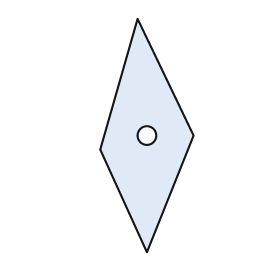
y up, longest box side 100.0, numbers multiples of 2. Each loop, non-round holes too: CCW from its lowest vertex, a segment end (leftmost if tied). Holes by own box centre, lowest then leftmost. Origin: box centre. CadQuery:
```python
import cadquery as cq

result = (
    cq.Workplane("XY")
    .moveTo(0.0, -50.0)
    .lineTo(20.0, 0.0)
    .lineTo(-4.0, 50.0)
    .lineTo(-20.0, -6.0)
    .close()
    .moveTo(0.0, 0.0)
    .circle(4.0)
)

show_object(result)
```